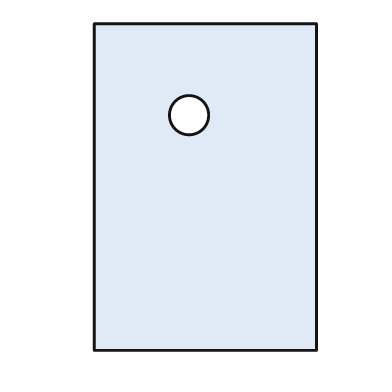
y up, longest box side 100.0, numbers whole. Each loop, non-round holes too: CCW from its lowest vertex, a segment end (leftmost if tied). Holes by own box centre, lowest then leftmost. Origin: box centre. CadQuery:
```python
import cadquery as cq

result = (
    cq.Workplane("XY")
    .moveTo(-34.0, -50.0)
    .lineTo(34.0, -50.0)
    .lineTo(34.0, 50.0)
    .lineTo(-34.0, 50.0)
    .close()
    .moveTo(-5.0, 22.0)
    .circle(6.0)
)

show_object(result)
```